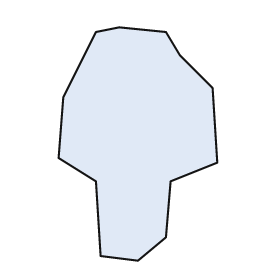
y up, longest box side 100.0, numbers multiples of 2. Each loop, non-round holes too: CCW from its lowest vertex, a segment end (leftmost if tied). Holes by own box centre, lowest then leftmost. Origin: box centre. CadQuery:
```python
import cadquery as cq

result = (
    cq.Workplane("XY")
    .moveTo(0.0, -50.0)
    .lineTo(12.0, -40.0)
    .lineTo(14.0, -16.0)
    .lineTo(34.0, -8.0)
    .lineTo(32.0, 24.0)
    .lineTo(18.0, 38.0)
    .lineTo(12.0, 48.0)
    .lineTo(-8.0, 50.0)
    .lineTo(-18.0, 48.0)
    .lineTo(-32.0, 20.0)
    .lineTo(-34.0, -6.0)
    .lineTo(-18.0, -16.0)
    .lineTo(-16.0, -48.0)
    .close()
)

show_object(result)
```